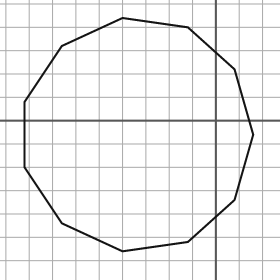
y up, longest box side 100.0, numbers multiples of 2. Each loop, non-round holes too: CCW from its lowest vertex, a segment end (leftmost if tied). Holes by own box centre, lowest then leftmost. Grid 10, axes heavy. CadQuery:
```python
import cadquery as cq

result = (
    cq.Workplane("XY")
    .moveTo(-40.0, -56.0)
    .lineTo(-12.0, -52.0)
    .lineTo(8.0, -34.0)
    .lineTo(16.0, -6.0)
    .lineTo(8.0, 22.0)
    .lineTo(-12.0, 40.0)
    .lineTo(-40.0, 44.0)
    .lineTo(-66.0, 32.0)
    .lineTo(-82.0, 8.0)
    .lineTo(-82.0, -20.0)
    .lineTo(-66.0, -44.0)
    .close()
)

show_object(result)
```